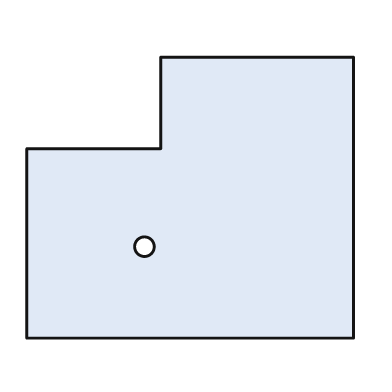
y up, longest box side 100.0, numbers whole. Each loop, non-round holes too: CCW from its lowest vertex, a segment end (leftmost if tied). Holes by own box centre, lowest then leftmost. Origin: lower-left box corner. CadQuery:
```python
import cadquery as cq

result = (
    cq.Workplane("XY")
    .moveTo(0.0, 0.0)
    .lineTo(100.0, 0.0)
    .lineTo(100.0, 86.0)
    .lineTo(41.0, 86.0)
    .lineTo(41.0, 58.0)
    .lineTo(0.0, 58.0)
    .close()
    .moveTo(36.0, 28.0)
    .circle(3.0)
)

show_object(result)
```